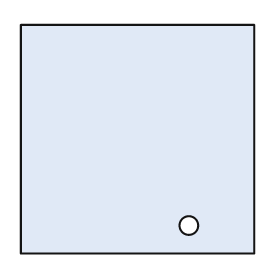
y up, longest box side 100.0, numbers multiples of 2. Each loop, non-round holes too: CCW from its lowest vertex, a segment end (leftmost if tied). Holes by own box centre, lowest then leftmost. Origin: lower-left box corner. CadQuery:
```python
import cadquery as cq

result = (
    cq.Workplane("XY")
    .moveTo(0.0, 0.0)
    .lineTo(100.0, 0.0)
    .lineTo(100.0, 98.0)
    .lineTo(0.0, 98.0)
    .close()
    .moveTo(72.0, 12.0)
    .circle(4.0)
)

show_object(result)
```